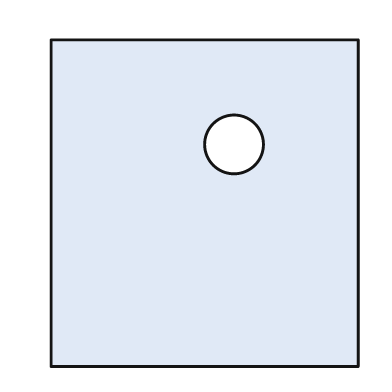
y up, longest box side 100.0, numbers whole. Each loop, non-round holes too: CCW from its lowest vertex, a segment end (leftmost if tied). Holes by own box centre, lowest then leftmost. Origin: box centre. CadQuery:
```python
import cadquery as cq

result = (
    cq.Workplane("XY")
    .moveTo(-47.0, -50.0)
    .lineTo(47.0, -50.0)
    .lineTo(47.0, 50.0)
    .lineTo(-47.0, 50.0)
    .close()
    .moveTo(9.0, 18.0)
    .circle(9.0)
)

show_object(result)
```